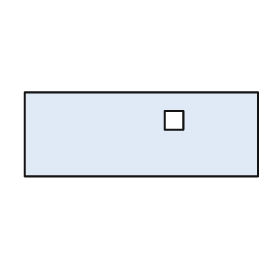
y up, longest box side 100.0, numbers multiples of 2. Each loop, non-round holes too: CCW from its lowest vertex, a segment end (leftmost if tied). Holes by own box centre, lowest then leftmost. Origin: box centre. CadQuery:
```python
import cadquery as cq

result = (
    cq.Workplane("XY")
    .moveTo(-50.0, -18.0)
    .lineTo(50.0, -18.0)
    .lineTo(50.0, 18.0)
    .lineTo(-50.0, 18.0)
    .close()
    .moveTo(10.0, 2.0)
    .lineTo(18.0, 2.0)
    .lineTo(18.0, 10.0)
    .lineTo(10.0, 10.0)
    .close()
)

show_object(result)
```